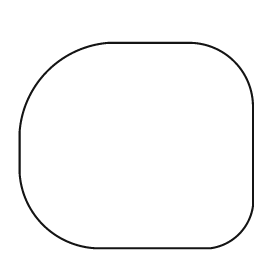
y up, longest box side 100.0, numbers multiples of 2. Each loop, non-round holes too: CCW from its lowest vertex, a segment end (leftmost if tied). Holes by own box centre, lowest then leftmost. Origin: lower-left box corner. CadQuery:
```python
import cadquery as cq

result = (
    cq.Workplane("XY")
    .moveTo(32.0, 0.0)
    .lineTo(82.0, 0.0)
    .threePointArc((94.0, 6.0), (100.0, 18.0))
    .lineTo(100.0, 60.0)
    .threePointArc((92.0, 80.0), (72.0, 88.0))
    .lineTo(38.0, 88.0)
    .threePointArc((12.0, 76.0), (0.0, 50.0))
    .lineTo(0.0, 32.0)
    .threePointArc((10.0, 10.0), (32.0, 0.0))
    .close()
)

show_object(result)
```